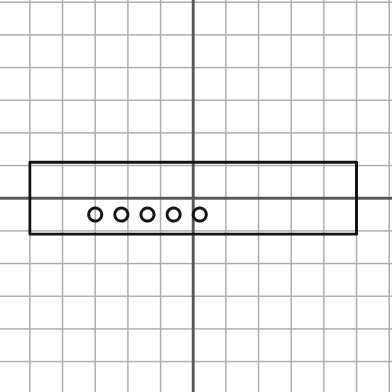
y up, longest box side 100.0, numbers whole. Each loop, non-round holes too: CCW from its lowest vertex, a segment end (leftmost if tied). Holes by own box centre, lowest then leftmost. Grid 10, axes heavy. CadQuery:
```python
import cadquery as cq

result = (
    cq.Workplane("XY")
    .moveTo(-50.0, -11.0)
    .lineTo(50.0, -11.0)
    .lineTo(50.0, 11.0)
    .lineTo(-50.0, 11.0)
    .close()
    .moveTo(-30.0, -5.0)
    .circle(2.0)
    .moveTo(-22.0, -5.0)
    .circle(2.0)
    .moveTo(-14.0, -5.0)
    .circle(2.0)
    .moveTo(-6.0, -5.0)
    .circle(2.0)
    .moveTo(2.0, -5.0)
    .circle(2.0)
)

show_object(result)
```